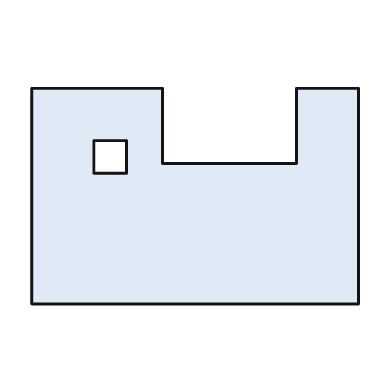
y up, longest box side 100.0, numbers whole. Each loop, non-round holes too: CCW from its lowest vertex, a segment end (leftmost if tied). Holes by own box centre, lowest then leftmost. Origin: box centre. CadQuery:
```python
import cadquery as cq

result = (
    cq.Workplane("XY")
    .moveTo(-50.0, -33.0)
    .lineTo(50.0, -33.0)
    .lineTo(50.0, 33.0)
    .lineTo(31.0, 33.0)
    .lineTo(31.0, 10.0)
    .lineTo(-10.0, 10.0)
    .lineTo(-10.0, 33.0)
    .lineTo(-50.0, 33.0)
    .close()
    .moveTo(-31.0, 7.0)
    .lineTo(-21.0, 7.0)
    .lineTo(-21.0, 17.0)
    .lineTo(-31.0, 17.0)
    .close()
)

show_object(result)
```